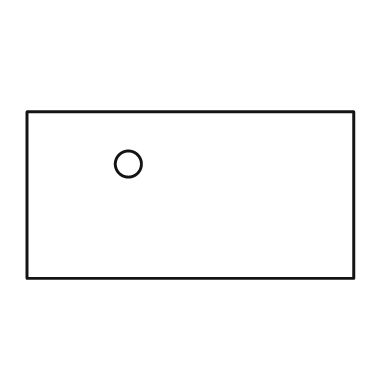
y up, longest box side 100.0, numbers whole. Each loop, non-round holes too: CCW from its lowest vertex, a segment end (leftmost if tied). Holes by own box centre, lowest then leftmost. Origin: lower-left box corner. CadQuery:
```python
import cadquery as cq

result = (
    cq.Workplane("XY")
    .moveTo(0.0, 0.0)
    .lineTo(100.0, 0.0)
    .lineTo(100.0, 51.0)
    .lineTo(0.0, 51.0)
    .close()
    .moveTo(31.0, 35.0)
    .circle(4.0)
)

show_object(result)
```